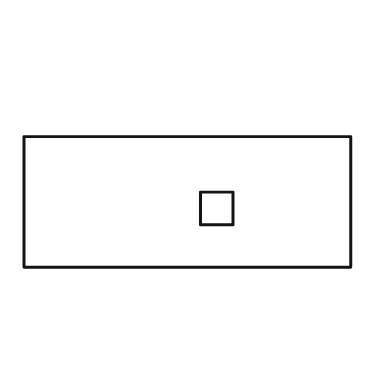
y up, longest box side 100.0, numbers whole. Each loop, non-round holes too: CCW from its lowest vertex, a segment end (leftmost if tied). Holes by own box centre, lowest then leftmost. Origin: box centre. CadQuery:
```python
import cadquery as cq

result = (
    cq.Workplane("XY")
    .moveTo(-50.0, -20.0)
    .lineTo(50.0, -20.0)
    .lineTo(50.0, 20.0)
    .lineTo(-50.0, 20.0)
    .close()
    .moveTo(4.0, -7.0)
    .lineTo(14.0, -7.0)
    .lineTo(14.0, 3.0)
    .lineTo(4.0, 3.0)
    .close()
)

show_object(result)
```